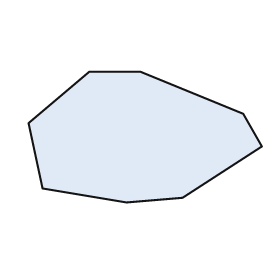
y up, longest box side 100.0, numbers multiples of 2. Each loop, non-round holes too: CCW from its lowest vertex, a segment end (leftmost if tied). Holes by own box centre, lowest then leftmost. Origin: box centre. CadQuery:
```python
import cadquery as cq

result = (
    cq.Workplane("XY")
    .moveTo(-8.0, -28.0)
    .lineTo(16.0, -26.0)
    .lineTo(50.0, -4.0)
    .lineTo(42.0, 10.0)
    .lineTo(-2.0, 28.0)
    .lineTo(-24.0, 28.0)
    .lineTo(-50.0, 6.0)
    .lineTo(-44.0, -22.0)
    .close()
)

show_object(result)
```